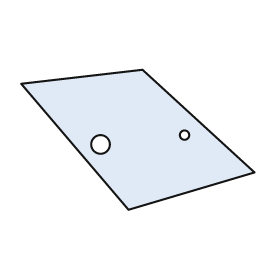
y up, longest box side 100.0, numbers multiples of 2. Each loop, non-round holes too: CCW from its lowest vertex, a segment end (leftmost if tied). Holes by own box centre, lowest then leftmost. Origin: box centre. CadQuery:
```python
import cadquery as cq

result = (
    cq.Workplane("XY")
    .moveTo(-4.0, -30.0)
    .lineTo(50.0, -14.0)
    .lineTo(2.0, 30.0)
    .lineTo(-50.0, 24.0)
    .close()
    .moveTo(-16.0, -2.0)
    .circle(4.0)
    .moveTo(20.0, 2.0)
    .circle(2.0)
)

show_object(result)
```